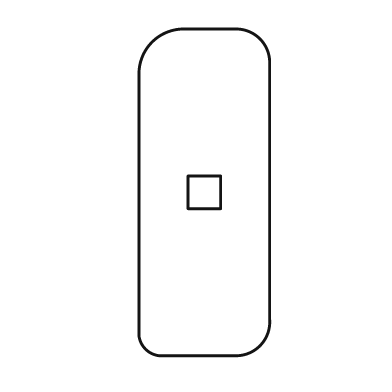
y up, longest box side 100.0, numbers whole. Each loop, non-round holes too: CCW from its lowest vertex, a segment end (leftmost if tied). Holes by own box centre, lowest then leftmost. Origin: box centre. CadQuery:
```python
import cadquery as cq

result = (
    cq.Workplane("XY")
    .moveTo(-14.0, -50.0)
    .lineTo(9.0, -50.0)
    .threePointArc((17.0, -47.0), (20.0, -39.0))
    .lineTo(20.0, 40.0)
    .threePointArc((17.0, 47.0), (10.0, 50.0))
    .lineTo(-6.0, 50.0)
    .threePointArc((-16.0, 46.0), (-20.0, 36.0))
    .lineTo(-20.0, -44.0)
    .threePointArc((-18.0, -48.0), (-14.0, -50.0))
    .close()
    .moveTo(-5.0, -5.0)
    .lineTo(5.0, -5.0)
    .lineTo(5.0, 5.0)
    .lineTo(-5.0, 5.0)
    .close()
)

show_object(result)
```